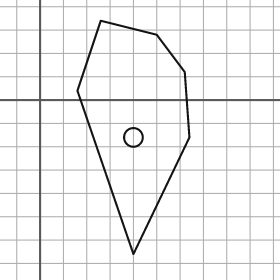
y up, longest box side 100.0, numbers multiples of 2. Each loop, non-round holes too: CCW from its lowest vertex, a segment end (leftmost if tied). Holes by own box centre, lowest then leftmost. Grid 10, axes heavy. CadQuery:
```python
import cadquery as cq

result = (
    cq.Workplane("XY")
    .moveTo(40.0, -66.0)
    .lineTo(64.0, -16.0)
    .lineTo(62.0, 12.0)
    .lineTo(50.0, 28.0)
    .lineTo(26.0, 34.0)
    .lineTo(16.0, 4.0)
    .close()
    .moveTo(40.0, -16.0)
    .circle(4.0)
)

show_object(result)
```